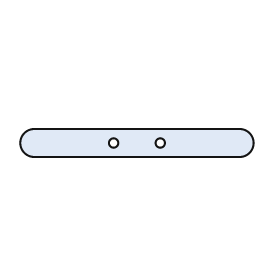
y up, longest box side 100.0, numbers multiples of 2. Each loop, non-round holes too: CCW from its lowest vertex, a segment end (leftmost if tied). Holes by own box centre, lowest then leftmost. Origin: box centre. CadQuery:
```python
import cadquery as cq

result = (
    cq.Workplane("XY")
    .moveTo(-44.0, -6.0)
    .lineTo(44.0, -6.0)
    .threePointArc((50.0, 0.0), (44.0, 6.0))
    .lineTo(-44.0, 6.0)
    .threePointArc((-50.0, 0.0), (-44.0, -6.0))
    .close()
    .moveTo(-10.0, 0.0)
    .circle(2.0)
    .moveTo(10.0, 0.0)
    .circle(2.0)
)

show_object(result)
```